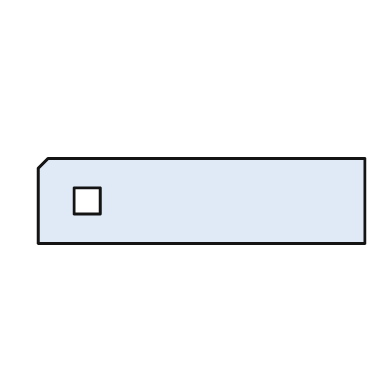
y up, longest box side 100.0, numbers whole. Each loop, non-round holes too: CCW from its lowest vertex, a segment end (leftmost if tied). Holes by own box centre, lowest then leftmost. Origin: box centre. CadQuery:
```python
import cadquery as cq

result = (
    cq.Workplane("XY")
    .moveTo(-50.0, -13.0)
    .lineTo(50.0, -13.0)
    .lineTo(50.0, 13.0)
    .lineTo(-47.0, 13.0)
    .lineTo(-50.0, 10.0)
    .close()
    .moveTo(-39.0, -4.0)
    .lineTo(-31.0, -4.0)
    .lineTo(-31.0, 4.0)
    .lineTo(-39.0, 4.0)
    .close()
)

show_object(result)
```